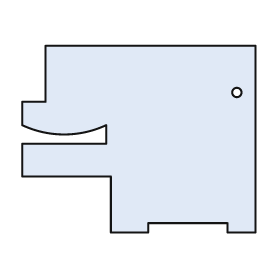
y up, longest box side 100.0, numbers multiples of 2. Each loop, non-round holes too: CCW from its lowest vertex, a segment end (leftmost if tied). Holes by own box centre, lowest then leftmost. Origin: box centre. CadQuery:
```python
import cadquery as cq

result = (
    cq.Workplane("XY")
    .moveTo(-12.0, -40.0)
    .lineTo(4.0, -40.0)
    .lineTo(4.0, -36.0)
    .lineTo(38.0, -36.0)
    .lineTo(38.0, -40.0)
    .lineTo(50.0, -40.0)
    .lineTo(50.0, 40.0)
    .lineTo(-40.0, 40.0)
    .lineTo(-40.0, 16.0)
    .lineTo(-50.0, 16.0)
    .lineTo(-50.0, 6.0)
    .threePointArc((-32.0, 2.0), (-14.0, 6.0))
    .lineTo(-14.0, -2.0)
    .lineTo(-50.0, -2.0)
    .lineTo(-50.0, -16.0)
    .lineTo(-12.0, -16.0)
    .close()
    .moveTo(42.0, 20.0)
    .circle(2.0)
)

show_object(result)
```